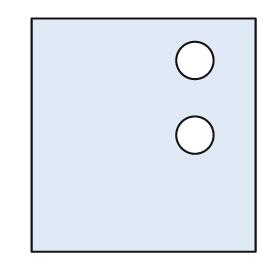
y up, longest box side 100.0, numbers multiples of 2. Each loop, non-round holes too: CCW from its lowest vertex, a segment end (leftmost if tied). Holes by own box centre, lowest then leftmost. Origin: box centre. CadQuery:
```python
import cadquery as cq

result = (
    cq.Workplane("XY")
    .moveTo(-48.0, -50.0)
    .lineTo(48.0, -50.0)
    .lineTo(48.0, 50.0)
    .lineTo(-48.0, 50.0)
    .close()
    .moveTo(22.0, 0.0)
    .circle(8.0)
    .moveTo(22.0, 32.0)
    .circle(8.0)
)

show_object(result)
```